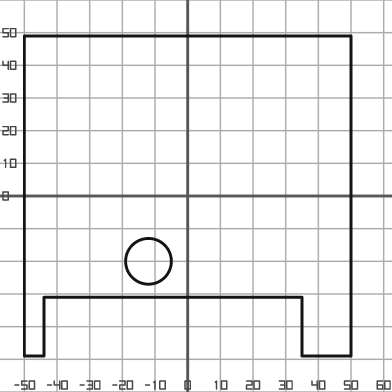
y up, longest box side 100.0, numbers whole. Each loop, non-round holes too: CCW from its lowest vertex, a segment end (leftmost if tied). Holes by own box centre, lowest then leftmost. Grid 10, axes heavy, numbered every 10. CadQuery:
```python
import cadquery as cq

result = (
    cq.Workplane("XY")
    .moveTo(-50.0, -49.0)
    .lineTo(-44.0, -49.0)
    .lineTo(-44.0, -31.0)
    .lineTo(35.0, -31.0)
    .lineTo(35.0, -49.0)
    .lineTo(50.0, -49.0)
    .lineTo(50.0, 49.0)
    .lineTo(-50.0, 49.0)
    .close()
    .moveTo(-12.0, -20.0)
    .circle(7.0)
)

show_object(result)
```